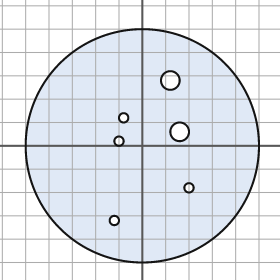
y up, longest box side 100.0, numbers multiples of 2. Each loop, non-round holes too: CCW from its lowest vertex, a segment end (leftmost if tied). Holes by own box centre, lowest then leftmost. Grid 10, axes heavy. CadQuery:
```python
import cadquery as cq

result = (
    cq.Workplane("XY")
    .moveTo(0.0, 0.0)
    .circle(50.0)
    .moveTo(-12.0, -32.0)
    .circle(2.0)
    .moveTo(20.0, -18.0)
    .circle(2.0)
    .moveTo(-10.0, 2.0)
    .circle(2.0)
    .moveTo(16.0, 6.0)
    .circle(4.0)
    .moveTo(-8.0, 12.0)
    .circle(2.0)
    .moveTo(12.0, 28.0)
    .circle(4.0)
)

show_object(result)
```